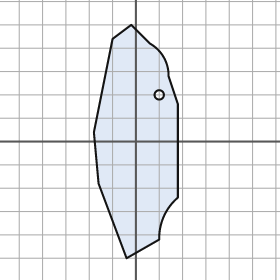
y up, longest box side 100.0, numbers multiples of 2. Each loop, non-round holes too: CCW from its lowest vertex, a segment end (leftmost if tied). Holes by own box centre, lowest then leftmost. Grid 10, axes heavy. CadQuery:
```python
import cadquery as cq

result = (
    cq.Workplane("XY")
    .moveTo(-4.0, -50.0)
    .lineTo(10.0, -42.0)
    .threePointArc((12.0, -32.0), (18.0, -24.0))
    .lineTo(18.0, 16.0)
    .lineTo(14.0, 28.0)
    .threePointArc((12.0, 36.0), (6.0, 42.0))
    .lineTo(-2.0, 50.0)
    .lineTo(-10.0, 44.0)
    .lineTo(-18.0, 4.0)
    .lineTo(-16.0, -18.0)
    .close()
    .moveTo(10.0, 20.0)
    .circle(2.0)
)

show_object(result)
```